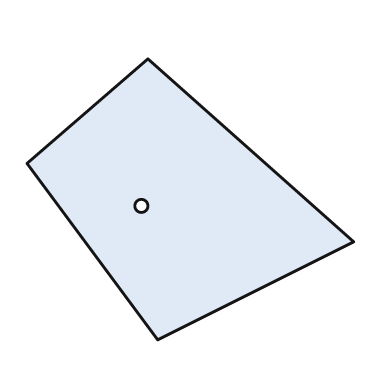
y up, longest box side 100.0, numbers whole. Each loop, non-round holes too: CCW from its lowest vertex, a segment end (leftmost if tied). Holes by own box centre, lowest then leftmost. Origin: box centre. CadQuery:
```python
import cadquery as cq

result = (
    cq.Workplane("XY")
    .moveTo(-10.0, -43.0)
    .lineTo(50.0, -13.0)
    .lineTo(-13.0, 43.0)
    .lineTo(-50.0, 11.0)
    .close()
    .moveTo(-15.0, -2.0)
    .circle(2.0)
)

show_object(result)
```